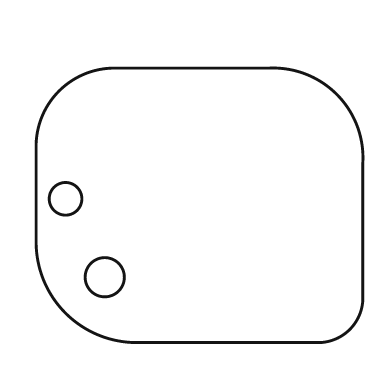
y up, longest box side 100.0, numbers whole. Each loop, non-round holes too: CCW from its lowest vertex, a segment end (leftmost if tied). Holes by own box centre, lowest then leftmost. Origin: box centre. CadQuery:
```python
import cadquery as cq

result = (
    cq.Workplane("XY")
    .moveTo(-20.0, -42.0)
    .lineTo(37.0, -42.0)
    .threePointArc((46.0, -38.0), (50.0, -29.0))
    .lineTo(50.0, 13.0)
    .threePointArc((42.0, 34.0), (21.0, 42.0))
    .lineTo(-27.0, 42.0)
    .threePointArc((-43.0, 35.0), (-50.0, 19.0))
    .lineTo(-50.0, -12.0)
    .threePointArc((-41.0, -33.0), (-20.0, -42.0))
    .close()
    .moveTo(-29.0, -22.0)
    .circle(6.0)
    .moveTo(-41.0, 2.0)
    .circle(5.0)
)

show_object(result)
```